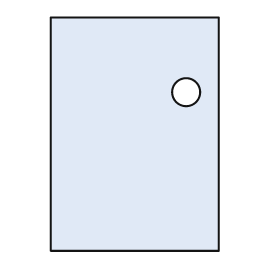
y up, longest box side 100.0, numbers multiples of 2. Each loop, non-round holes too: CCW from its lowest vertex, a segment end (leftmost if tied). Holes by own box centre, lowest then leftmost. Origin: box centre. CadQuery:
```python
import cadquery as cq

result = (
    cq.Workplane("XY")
    .moveTo(-36.0, -50.0)
    .lineTo(36.0, -50.0)
    .lineTo(36.0, 50.0)
    .lineTo(-36.0, 50.0)
    .close()
    .moveTo(22.0, 18.0)
    .circle(6.0)
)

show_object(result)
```